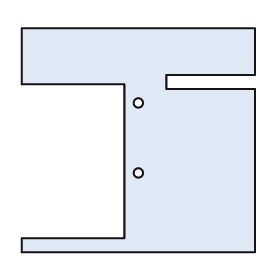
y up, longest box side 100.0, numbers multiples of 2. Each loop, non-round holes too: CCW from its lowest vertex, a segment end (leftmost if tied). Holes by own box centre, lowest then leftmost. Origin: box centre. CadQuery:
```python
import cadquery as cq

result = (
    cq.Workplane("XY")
    .moveTo(-50.0, -48.0)
    .lineTo(50.0, -48.0)
    .lineTo(50.0, 22.0)
    .lineTo(12.0, 22.0)
    .lineTo(12.0, 28.0)
    .lineTo(50.0, 28.0)
    .lineTo(50.0, 48.0)
    .lineTo(-50.0, 48.0)
    .lineTo(-50.0, 24.0)
    .lineTo(-6.0, 24.0)
    .lineTo(-6.0, -42.0)
    .lineTo(-50.0, -42.0)
    .close()
    .moveTo(0.0, -14.0)
    .circle(2.0)
    .moveTo(0.0, 16.0)
    .circle(2.0)
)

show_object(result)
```